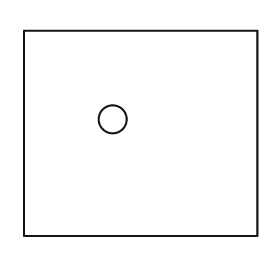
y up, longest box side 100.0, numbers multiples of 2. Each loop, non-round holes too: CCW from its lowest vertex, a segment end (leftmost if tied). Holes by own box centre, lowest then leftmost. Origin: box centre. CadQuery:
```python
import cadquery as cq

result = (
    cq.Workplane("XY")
    .moveTo(-50.0, -44.0)
    .lineTo(50.0, -44.0)
    .lineTo(50.0, 44.0)
    .lineTo(-50.0, 44.0)
    .close()
    .moveTo(-12.0, 6.0)
    .circle(6.0)
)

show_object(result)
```